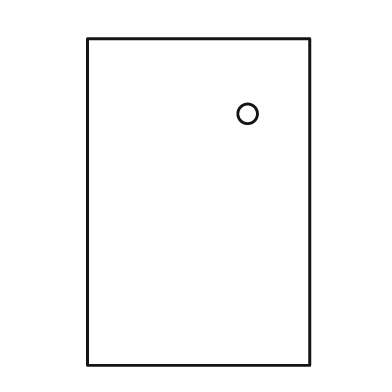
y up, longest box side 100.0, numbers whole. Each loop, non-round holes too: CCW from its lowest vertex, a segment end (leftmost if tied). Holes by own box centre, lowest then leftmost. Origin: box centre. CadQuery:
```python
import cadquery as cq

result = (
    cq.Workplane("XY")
    .moveTo(-34.0, -50.0)
    .lineTo(34.0, -50.0)
    .lineTo(34.0, 50.0)
    .lineTo(-34.0, 50.0)
    .close()
    .moveTo(15.0, 27.0)
    .circle(3.0)
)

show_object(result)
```